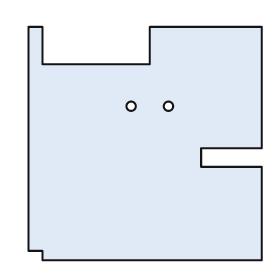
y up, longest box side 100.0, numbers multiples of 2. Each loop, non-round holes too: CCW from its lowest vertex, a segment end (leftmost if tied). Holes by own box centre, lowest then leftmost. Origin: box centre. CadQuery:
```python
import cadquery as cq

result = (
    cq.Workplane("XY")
    .moveTo(-44.0, -50.0)
    .lineTo(50.0, -50.0)
    .lineTo(50.0, -10.0)
    .lineTo(24.0, -10.0)
    .lineTo(24.0, -2.0)
    .lineTo(50.0, -2.0)
    .lineTo(50.0, 50.0)
    .lineTo(2.0, 50.0)
    .lineTo(2.0, 34.0)
    .lineTo(-44.0, 34.0)
    .lineTo(-44.0, 50.0)
    .lineTo(-50.0, 50.0)
    .lineTo(-50.0, -46.0)
    .lineTo(-44.0, -46.0)
    .close()
    .moveTo(-6.0, 16.0)
    .circle(2.0)
    .moveTo(10.0, 16.0)
    .circle(2.0)
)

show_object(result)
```